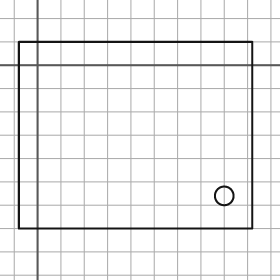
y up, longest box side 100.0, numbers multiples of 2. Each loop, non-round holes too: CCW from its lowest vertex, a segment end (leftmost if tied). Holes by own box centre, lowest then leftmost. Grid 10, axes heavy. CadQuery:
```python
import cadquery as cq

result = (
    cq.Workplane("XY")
    .moveTo(-8.0, -70.0)
    .lineTo(92.0, -70.0)
    .lineTo(92.0, 10.0)
    .lineTo(-8.0, 10.0)
    .close()
    .moveTo(80.0, -56.0)
    .circle(4.0)
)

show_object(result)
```